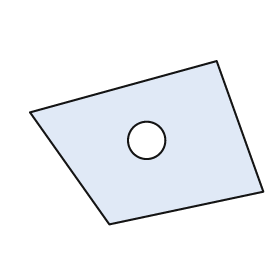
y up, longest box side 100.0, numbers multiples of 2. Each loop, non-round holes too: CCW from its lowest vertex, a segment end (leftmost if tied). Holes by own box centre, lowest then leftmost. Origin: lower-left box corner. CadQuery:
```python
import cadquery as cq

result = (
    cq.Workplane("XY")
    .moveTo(34.0, 0.0)
    .lineTo(100.0, 14.0)
    .lineTo(80.0, 70.0)
    .lineTo(0.0, 48.0)
    .close()
    .moveTo(50.0, 36.0)
    .circle(8.0)
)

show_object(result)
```